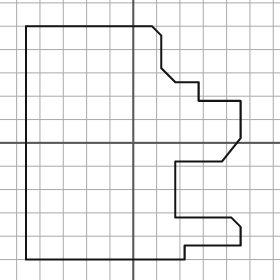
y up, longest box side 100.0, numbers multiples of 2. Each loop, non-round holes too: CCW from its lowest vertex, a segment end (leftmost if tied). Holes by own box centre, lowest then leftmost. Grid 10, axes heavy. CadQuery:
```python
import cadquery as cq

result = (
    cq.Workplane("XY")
    .moveTo(-46.0, -50.0)
    .lineTo(22.0, -50.0)
    .lineTo(22.0, -44.0)
    .lineTo(46.0, -44.0)
    .lineTo(46.0, -36.0)
    .lineTo(42.0, -32.0)
    .lineTo(18.0, -32.0)
    .lineTo(18.0, -8.0)
    .lineTo(38.0, -8.0)
    .lineTo(46.0, 2.0)
    .lineTo(46.0, 18.0)
    .lineTo(28.0, 18.0)
    .lineTo(28.0, 26.0)
    .lineTo(18.0, 26.0)
    .lineTo(12.0, 32.0)
    .lineTo(12.0, 46.0)
    .lineTo(8.0, 50.0)
    .lineTo(-46.0, 50.0)
    .close()
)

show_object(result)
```